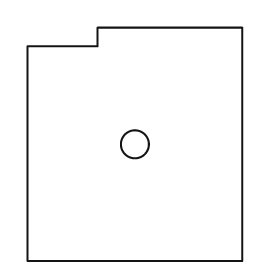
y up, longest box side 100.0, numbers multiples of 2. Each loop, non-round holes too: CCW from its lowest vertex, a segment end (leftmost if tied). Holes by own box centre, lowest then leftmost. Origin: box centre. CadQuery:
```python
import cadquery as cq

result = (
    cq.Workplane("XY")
    .moveTo(-46.0, -50.0)
    .lineTo(46.0, -50.0)
    .lineTo(46.0, 50.0)
    .lineTo(-16.0, 50.0)
    .lineTo(-16.0, 42.0)
    .lineTo(-46.0, 42.0)
    .close()
    .moveTo(0.0, 0.0)
    .circle(6.0)
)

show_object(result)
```